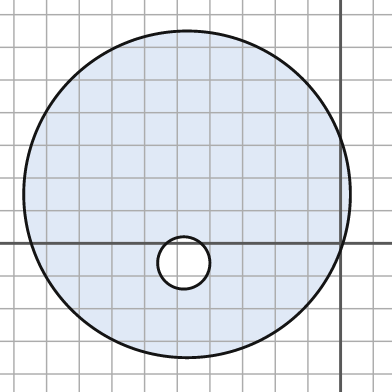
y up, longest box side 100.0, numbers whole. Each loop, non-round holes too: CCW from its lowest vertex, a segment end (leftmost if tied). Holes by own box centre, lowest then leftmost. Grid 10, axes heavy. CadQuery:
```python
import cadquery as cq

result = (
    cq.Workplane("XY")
    .moveTo(-47.0, 15.0)
    .circle(50.0)
    .moveTo(-48.0, -6.0)
    .circle(8.0)
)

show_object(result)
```